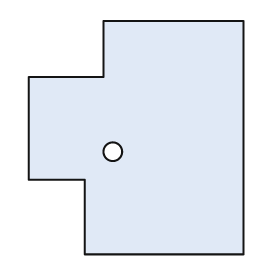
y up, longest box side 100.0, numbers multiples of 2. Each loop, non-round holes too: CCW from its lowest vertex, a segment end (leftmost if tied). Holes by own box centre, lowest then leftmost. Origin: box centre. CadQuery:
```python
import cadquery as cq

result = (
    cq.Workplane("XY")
    .moveTo(-22.0, -50.0)
    .lineTo(46.0, -50.0)
    .lineTo(46.0, 50.0)
    .lineTo(-14.0, 50.0)
    .lineTo(-14.0, 26.0)
    .lineTo(-46.0, 26.0)
    .lineTo(-46.0, -18.0)
    .lineTo(-22.0, -18.0)
    .close()
    .moveTo(-10.0, -6.0)
    .circle(4.0)
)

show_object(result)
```